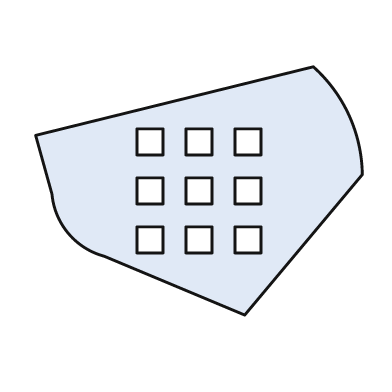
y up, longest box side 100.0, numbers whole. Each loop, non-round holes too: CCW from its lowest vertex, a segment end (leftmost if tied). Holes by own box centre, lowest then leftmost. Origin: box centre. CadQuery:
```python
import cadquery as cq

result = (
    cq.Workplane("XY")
    .moveTo(14.0, -38.0)
    .lineTo(50.0, 5.0)
    .threePointArc((46.0, 23.0), (35.0, 38.0))
    .lineTo(-50.0, 17.0)
    .lineTo(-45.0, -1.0)
    .threePointArc((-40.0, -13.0), (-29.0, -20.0))
    .close()
    .moveTo(-19.0, -19.0)
    .lineTo(-11.0, -19.0)
    .lineTo(-11.0, -11.0)
    .lineTo(-19.0, -11.0)
    .close()
    .moveTo(-4.0, -19.0)
    .lineTo(4.0, -19.0)
    .lineTo(4.0, -11.0)
    .lineTo(-4.0, -11.0)
    .close()
    .moveTo(11.0, -19.0)
    .lineTo(19.0, -19.0)
    .lineTo(19.0, -11.0)
    .lineTo(11.0, -11.0)
    .close()
    .moveTo(-19.0, -4.0)
    .lineTo(-11.0, -4.0)
    .lineTo(-11.0, 4.0)
    .lineTo(-19.0, 4.0)
    .close()
    .moveTo(-4.0, -4.0)
    .lineTo(4.0, -4.0)
    .lineTo(4.0, 4.0)
    .lineTo(-4.0, 4.0)
    .close()
    .moveTo(11.0, -4.0)
    .lineTo(19.0, -4.0)
    .lineTo(19.0, 4.0)
    .lineTo(11.0, 4.0)
    .close()
    .moveTo(-19.0, 11.0)
    .lineTo(-11.0, 11.0)
    .lineTo(-11.0, 19.0)
    .lineTo(-19.0, 19.0)
    .close()
    .moveTo(-4.0, 11.0)
    .lineTo(4.0, 11.0)
    .lineTo(4.0, 19.0)
    .lineTo(-4.0, 19.0)
    .close()
    .moveTo(11.0, 11.0)
    .lineTo(19.0, 11.0)
    .lineTo(19.0, 19.0)
    .lineTo(11.0, 19.0)
    .close()
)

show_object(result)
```